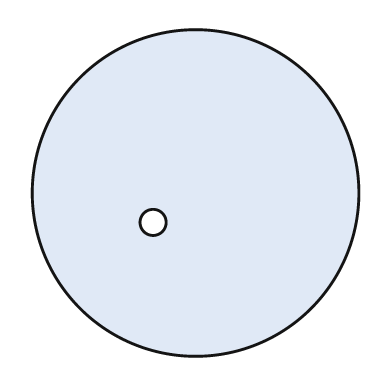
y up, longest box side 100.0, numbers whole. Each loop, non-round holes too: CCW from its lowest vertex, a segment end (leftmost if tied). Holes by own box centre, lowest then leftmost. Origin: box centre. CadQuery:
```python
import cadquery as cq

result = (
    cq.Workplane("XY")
    .moveTo(0.0, 0.0)
    .circle(50.0)
    .moveTo(-13.0, -9.0)
    .circle(4.0)
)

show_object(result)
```